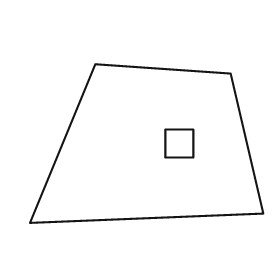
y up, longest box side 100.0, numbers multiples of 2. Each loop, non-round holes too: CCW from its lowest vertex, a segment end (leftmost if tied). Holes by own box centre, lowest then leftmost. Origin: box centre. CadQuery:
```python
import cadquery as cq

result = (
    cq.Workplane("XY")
    .moveTo(-50.0, -34.0)
    .lineTo(50.0, -30.0)
    .lineTo(36.0, 30.0)
    .lineTo(-22.0, 34.0)
    .close()
    .moveTo(8.0, -6.0)
    .lineTo(20.0, -6.0)
    .lineTo(20.0, 6.0)
    .lineTo(8.0, 6.0)
    .close()
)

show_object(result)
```